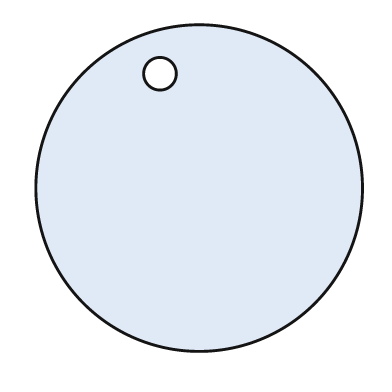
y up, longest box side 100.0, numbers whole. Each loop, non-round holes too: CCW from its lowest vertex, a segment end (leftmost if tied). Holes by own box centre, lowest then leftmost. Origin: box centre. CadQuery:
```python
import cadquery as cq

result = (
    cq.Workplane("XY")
    .moveTo(0.0, 0.0)
    .circle(50.0)
    .moveTo(-12.0, 35.0)
    .circle(5.0)
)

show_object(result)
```